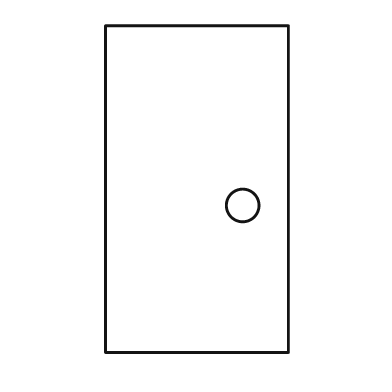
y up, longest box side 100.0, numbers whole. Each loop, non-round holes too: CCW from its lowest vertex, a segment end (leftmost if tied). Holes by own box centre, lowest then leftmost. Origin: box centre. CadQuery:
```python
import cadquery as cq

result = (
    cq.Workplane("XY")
    .moveTo(-28.0, -50.0)
    .lineTo(28.0, -50.0)
    .lineTo(28.0, 50.0)
    .lineTo(-28.0, 50.0)
    .close()
    .moveTo(14.0, -5.0)
    .circle(5.0)
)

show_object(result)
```